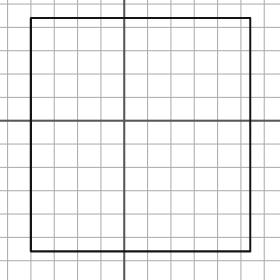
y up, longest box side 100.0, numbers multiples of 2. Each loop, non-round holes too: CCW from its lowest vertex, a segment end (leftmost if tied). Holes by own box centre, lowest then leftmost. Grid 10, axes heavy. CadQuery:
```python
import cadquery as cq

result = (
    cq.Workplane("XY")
    .moveTo(-40.0, -56.0)
    .lineTo(54.0, -56.0)
    .lineTo(54.0, 44.0)
    .lineTo(-40.0, 44.0)
    .close()
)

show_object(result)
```